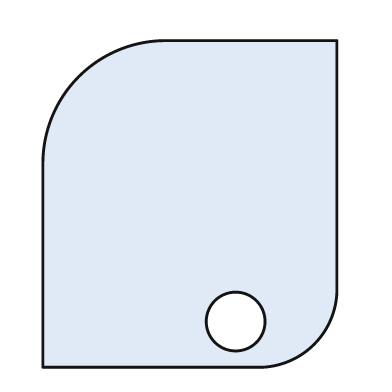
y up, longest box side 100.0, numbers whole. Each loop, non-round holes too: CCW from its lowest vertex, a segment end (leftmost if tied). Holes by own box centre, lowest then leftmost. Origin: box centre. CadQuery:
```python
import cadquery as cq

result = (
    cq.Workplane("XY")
    .moveTo(-45.0, -50.0)
    .lineTo(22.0, -50.0)
    .threePointArc((38.0, -43.0), (45.0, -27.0))
    .lineTo(45.0, 50.0)
    .lineTo(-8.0, 50.0)
    .threePointArc((-34.0, 39.0), (-45.0, 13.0))
    .close()
    .moveTo(14.0, -36.0)
    .circle(9.0)
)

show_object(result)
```